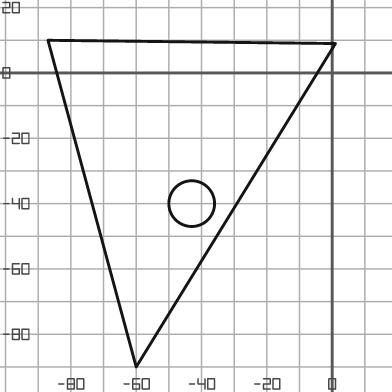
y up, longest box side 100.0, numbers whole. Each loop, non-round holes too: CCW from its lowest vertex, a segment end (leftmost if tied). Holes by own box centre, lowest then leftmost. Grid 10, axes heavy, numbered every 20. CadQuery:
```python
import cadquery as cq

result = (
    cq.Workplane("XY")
    .moveTo(-60.0, -90.0)
    .lineTo(1.0, 9.0)
    .lineTo(-87.0, 10.0)
    .close()
    .moveTo(-43.0, -40.0)
    .circle(7.0)
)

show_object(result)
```